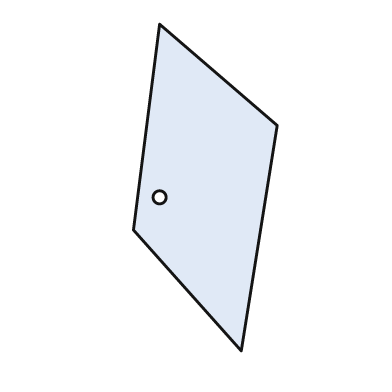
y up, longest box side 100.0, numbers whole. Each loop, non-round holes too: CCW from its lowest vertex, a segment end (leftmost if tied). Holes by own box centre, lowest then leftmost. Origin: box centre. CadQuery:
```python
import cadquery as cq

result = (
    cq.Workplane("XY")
    .moveTo(11.0, -50.0)
    .lineTo(22.0, 19.0)
    .lineTo(-14.0, 50.0)
    .lineTo(-22.0, -13.0)
    .close()
    .moveTo(-14.0, -3.0)
    .circle(2.0)
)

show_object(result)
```